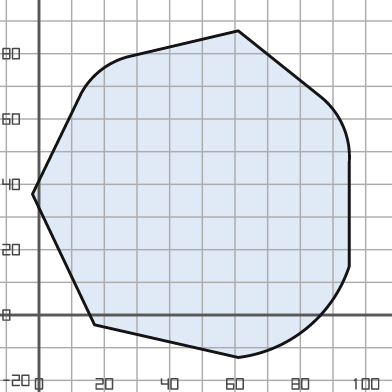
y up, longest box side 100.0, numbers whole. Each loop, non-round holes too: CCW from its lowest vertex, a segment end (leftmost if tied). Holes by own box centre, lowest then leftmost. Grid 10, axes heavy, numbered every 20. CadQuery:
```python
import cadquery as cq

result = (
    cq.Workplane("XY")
    .moveTo(61.0, -13.0)
    .threePointArc((82.0, -4.0), (95.0, 15.0))
    .lineTo(95.0, 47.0)
    .threePointArc((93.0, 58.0), (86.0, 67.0))
    .lineTo(61.0, 87.0)
    .lineTo(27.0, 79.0)
    .threePointArc((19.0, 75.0), (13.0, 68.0))
    .lineTo(-2.0, 37.0)
    .lineTo(17.0, -3.0)
    .close()
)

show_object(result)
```